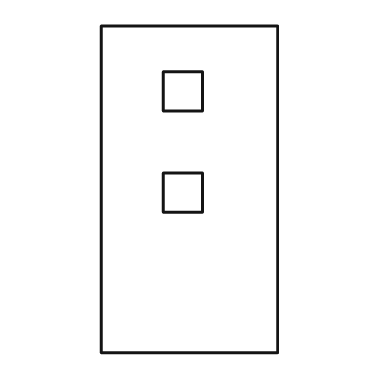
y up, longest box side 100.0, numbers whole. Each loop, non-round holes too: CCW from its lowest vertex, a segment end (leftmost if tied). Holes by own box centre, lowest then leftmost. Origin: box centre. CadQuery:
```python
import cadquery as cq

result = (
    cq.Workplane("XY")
    .moveTo(-27.0, -50.0)
    .lineTo(27.0, -50.0)
    .lineTo(27.0, 50.0)
    .lineTo(-27.0, 50.0)
    .close()
    .moveTo(-8.0, -7.0)
    .lineTo(4.0, -7.0)
    .lineTo(4.0, 5.0)
    .lineTo(-8.0, 5.0)
    .close()
    .moveTo(-8.0, 24.0)
    .lineTo(4.0, 24.0)
    .lineTo(4.0, 36.0)
    .lineTo(-8.0, 36.0)
    .close()
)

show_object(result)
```